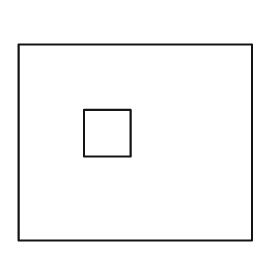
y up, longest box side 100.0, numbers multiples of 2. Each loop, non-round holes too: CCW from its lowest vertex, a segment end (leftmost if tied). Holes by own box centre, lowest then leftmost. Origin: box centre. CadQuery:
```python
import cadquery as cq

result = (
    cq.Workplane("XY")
    .moveTo(-50.0, -42.0)
    .lineTo(50.0, -42.0)
    .lineTo(50.0, 42.0)
    .lineTo(-50.0, 42.0)
    .close()
    .moveTo(-22.0, -6.0)
    .lineTo(-2.0, -6.0)
    .lineTo(-2.0, 14.0)
    .lineTo(-22.0, 14.0)
    .close()
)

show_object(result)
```